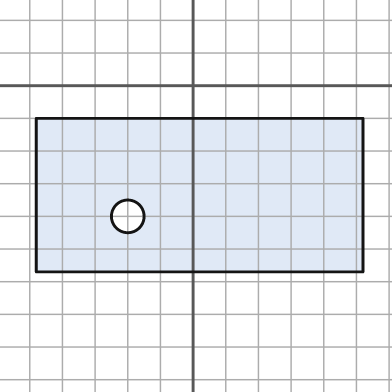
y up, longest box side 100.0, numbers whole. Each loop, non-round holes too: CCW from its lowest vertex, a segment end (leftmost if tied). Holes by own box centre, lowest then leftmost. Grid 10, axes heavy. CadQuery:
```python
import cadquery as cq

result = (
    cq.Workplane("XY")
    .moveTo(-48.0, -57.0)
    .lineTo(52.0, -57.0)
    .lineTo(52.0, -10.0)
    .lineTo(-48.0, -10.0)
    .close()
    .moveTo(-20.0, -40.0)
    .circle(5.0)
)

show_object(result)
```